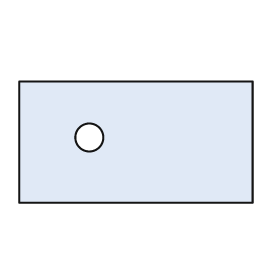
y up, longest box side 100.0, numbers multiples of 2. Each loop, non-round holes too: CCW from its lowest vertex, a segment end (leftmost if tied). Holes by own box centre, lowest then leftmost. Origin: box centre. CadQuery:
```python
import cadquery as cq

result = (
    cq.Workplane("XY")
    .moveTo(-50.0, -26.0)
    .lineTo(50.0, -26.0)
    .lineTo(50.0, 26.0)
    .lineTo(-50.0, 26.0)
    .close()
    .moveTo(-20.0, 2.0)
    .circle(6.0)
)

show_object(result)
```